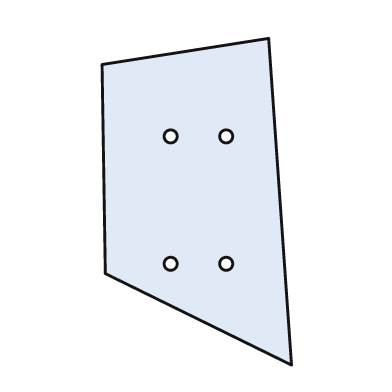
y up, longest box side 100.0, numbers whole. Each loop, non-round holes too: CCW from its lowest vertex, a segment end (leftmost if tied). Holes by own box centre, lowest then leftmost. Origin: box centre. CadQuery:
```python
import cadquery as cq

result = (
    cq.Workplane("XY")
    .moveTo(29.0, -50.0)
    .lineTo(22.0, 50.0)
    .lineTo(-29.0, 42.0)
    .lineTo(-28.0, -22.0)
    .close()
    .moveTo(-8.0, -19.0)
    .circle(2.0)
    .moveTo(9.0, -19.0)
    .circle(2.0)
    .moveTo(-8.0, 20.0)
    .circle(2.0)
    .moveTo(9.0, 20.0)
    .circle(2.0)
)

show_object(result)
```